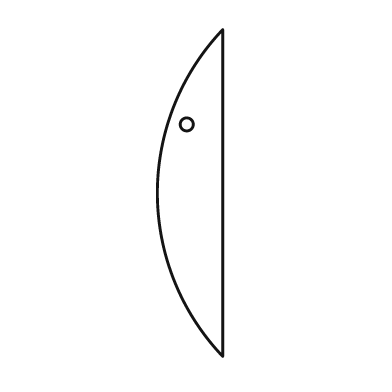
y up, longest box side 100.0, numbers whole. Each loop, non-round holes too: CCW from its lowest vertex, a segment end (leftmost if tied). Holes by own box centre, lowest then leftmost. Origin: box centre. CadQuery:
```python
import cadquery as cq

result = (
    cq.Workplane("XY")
    .moveTo(10.0, -50.0)
    .lineTo(10.0, 50.0)
    .threePointArc((-10.0, 0.0), (10.0, -50.0))
    .close()
    .moveTo(-1.0, 21.0)
    .circle(2.0)
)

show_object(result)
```